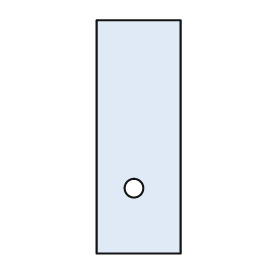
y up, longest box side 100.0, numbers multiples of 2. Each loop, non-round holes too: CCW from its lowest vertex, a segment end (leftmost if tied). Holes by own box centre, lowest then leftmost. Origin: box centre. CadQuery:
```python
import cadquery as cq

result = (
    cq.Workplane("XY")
    .moveTo(-18.0, -50.0)
    .lineTo(18.0, -50.0)
    .lineTo(18.0, 50.0)
    .lineTo(-18.0, 50.0)
    .close()
    .moveTo(-2.0, -22.0)
    .circle(4.0)
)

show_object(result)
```